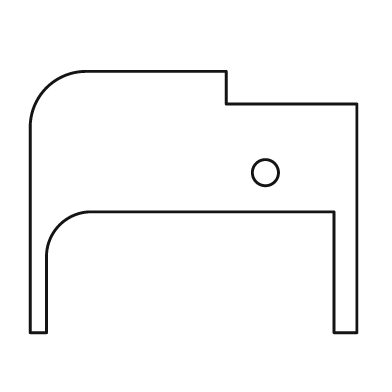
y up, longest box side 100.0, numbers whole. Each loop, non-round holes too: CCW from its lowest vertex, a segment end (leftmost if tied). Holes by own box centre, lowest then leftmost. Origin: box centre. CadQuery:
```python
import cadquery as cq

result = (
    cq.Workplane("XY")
    .moveTo(-50.0, -40.0)
    .lineTo(-45.0, -40.0)
    .lineTo(-45.0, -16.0)
    .threePointArc((-41.0, -7.0), (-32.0, -3.0))
    .lineTo(43.0, -3.0)
    .lineTo(43.0, -40.0)
    .lineTo(50.0, -40.0)
    .lineTo(50.0, 30.0)
    .lineTo(10.0, 30.0)
    .lineTo(10.0, 40.0)
    .lineTo(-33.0, 40.0)
    .threePointArc((-45.0, 35.0), (-50.0, 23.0))
    .close()
    .moveTo(22.0, 9.0)
    .circle(4.0)
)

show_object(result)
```